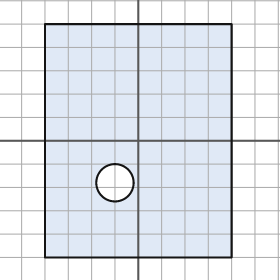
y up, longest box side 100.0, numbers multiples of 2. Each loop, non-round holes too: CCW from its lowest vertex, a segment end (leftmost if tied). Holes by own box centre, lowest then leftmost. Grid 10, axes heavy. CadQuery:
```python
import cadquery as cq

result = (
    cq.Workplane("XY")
    .moveTo(-40.0, -50.0)
    .lineTo(40.0, -50.0)
    .lineTo(40.0, 50.0)
    .lineTo(-40.0, 50.0)
    .close()
    .moveTo(-10.0, -18.0)
    .circle(8.0)
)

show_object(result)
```